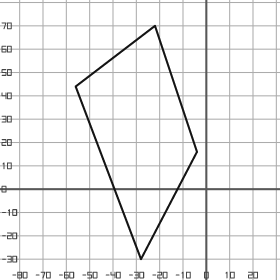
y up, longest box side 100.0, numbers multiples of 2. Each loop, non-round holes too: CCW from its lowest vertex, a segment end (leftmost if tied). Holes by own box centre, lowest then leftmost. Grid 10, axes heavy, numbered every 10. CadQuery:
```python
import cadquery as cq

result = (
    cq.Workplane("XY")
    .moveTo(-28.0, -30.0)
    .lineTo(-4.0, 16.0)
    .lineTo(-22.0, 70.0)
    .lineTo(-56.0, 44.0)
    .close()
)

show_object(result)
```